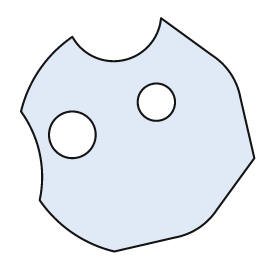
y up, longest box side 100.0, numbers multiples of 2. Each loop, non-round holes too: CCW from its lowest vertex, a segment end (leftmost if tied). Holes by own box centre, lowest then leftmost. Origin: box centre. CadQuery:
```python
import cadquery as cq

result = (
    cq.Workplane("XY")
    .moveTo(-10.0, -50.0)
    .lineTo(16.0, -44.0)
    .threePointArc((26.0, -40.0), (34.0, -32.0))
    .lineTo(50.0, -10.0)
    .lineTo(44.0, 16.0)
    .threePointArc((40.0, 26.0), (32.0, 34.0))
    .lineTo(10.0, 50.0)
    .threePointArc((-6.0, 32.0), (-28.0, 42.0))
    .threePointArc((-42.0, 28.0), (-50.0, 10.0))
    .threePointArc((-42.0, -8.0), (-42.0, -28.0))
    .threePointArc((-28.0, -42.0), (-10.0, -50.0))
    .close()
    .moveTo(-28.0, 0.0)
    .circle(10.0)
    .moveTo(8.0, 14.0)
    .circle(8.0)
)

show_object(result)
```